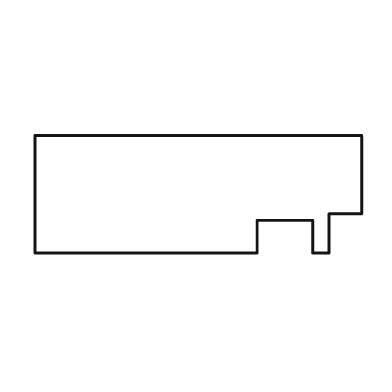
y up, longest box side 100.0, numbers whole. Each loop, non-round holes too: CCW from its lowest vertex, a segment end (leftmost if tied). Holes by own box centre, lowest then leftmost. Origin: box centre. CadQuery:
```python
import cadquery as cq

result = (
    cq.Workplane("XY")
    .moveTo(-50.0, -18.0)
    .lineTo(18.0, -18.0)
    .lineTo(18.0, -8.0)
    .lineTo(35.0, -8.0)
    .lineTo(35.0, -18.0)
    .lineTo(40.0, -18.0)
    .lineTo(40.0, -6.0)
    .lineTo(50.0, -6.0)
    .lineTo(50.0, 18.0)
    .lineTo(-50.0, 18.0)
    .close()
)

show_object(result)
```